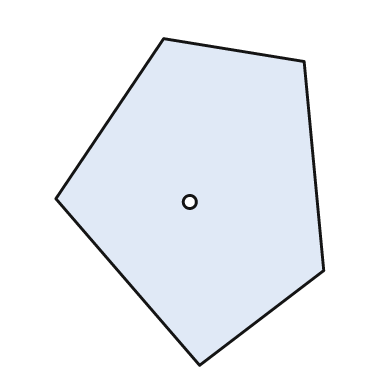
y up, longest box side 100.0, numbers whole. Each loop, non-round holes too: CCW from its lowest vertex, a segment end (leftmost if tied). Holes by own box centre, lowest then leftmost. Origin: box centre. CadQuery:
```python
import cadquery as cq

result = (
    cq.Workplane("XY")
    .moveTo(3.0, -50.0)
    .lineTo(41.0, -21.0)
    .lineTo(35.0, 43.0)
    .lineTo(-8.0, 50.0)
    .lineTo(-41.0, 1.0)
    .close()
    .moveTo(0.0, 0.0)
    .circle(2.0)
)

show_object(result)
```